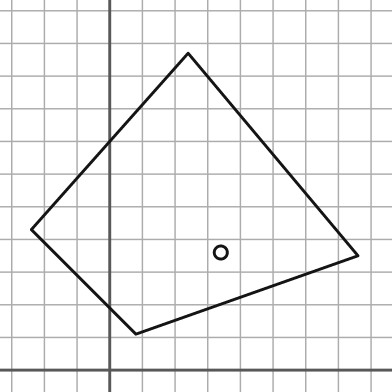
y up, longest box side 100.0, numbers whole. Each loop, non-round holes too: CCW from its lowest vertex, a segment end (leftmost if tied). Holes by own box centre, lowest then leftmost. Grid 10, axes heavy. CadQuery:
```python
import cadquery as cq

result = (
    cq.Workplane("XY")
    .moveTo(8.0, 11.0)
    .lineTo(76.0, 35.0)
    .lineTo(24.0, 97.0)
    .lineTo(-24.0, 43.0)
    .close()
    .moveTo(34.0, 36.0)
    .circle(2.0)
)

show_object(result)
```